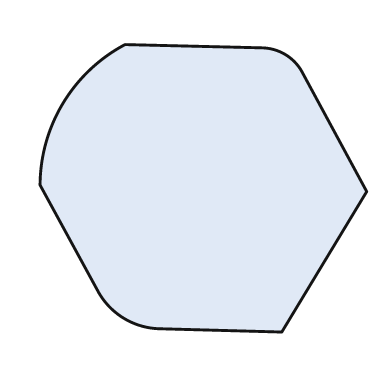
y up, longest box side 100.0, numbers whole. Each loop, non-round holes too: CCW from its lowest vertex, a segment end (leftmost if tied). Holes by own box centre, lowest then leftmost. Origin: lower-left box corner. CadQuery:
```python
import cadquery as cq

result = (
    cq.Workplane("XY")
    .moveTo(74.0, 0.0)
    .lineTo(100.0, 43.0)
    .lineTo(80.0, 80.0)
    .threePointArc((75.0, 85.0), (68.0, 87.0))
    .lineTo(26.0, 88.0)
    .threePointArc((7.0, 70.0), (0.0, 45.0))
    .lineTo(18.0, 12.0)
    .threePointArc((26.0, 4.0), (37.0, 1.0))
    .close()
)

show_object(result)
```